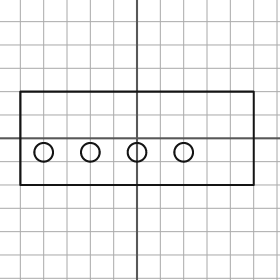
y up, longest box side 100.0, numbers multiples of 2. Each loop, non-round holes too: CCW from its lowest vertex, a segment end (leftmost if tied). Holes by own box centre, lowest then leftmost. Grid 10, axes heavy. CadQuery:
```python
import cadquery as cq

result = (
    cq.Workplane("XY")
    .moveTo(-50.0, -20.0)
    .lineTo(50.0, -20.0)
    .lineTo(50.0, 20.0)
    .lineTo(-50.0, 20.0)
    .close()
    .moveTo(-40.0, -6.0)
    .circle(4.0)
    .moveTo(-20.0, -6.0)
    .circle(4.0)
    .moveTo(0.0, -6.0)
    .circle(4.0)
    .moveTo(20.0, -6.0)
    .circle(4.0)
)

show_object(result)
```